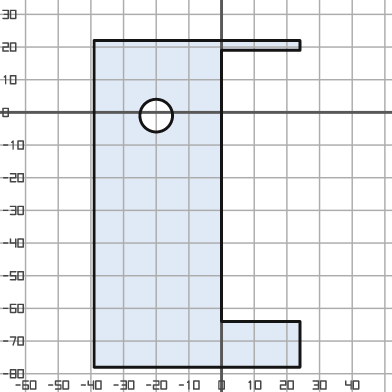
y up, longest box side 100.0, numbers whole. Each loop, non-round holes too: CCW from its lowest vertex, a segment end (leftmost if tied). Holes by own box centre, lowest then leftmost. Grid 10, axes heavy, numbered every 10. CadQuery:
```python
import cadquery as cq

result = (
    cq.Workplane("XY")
    .moveTo(-39.0, -78.0)
    .lineTo(24.0, -78.0)
    .lineTo(24.0, -64.0)
    .lineTo(0.0, -64.0)
    .lineTo(0.0, 19.0)
    .lineTo(24.0, 19.0)
    .lineTo(24.0, 22.0)
    .lineTo(-39.0, 22.0)
    .close()
    .moveTo(-20.0, -1.0)
    .circle(5.0)
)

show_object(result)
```